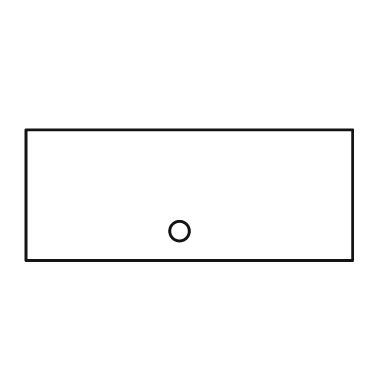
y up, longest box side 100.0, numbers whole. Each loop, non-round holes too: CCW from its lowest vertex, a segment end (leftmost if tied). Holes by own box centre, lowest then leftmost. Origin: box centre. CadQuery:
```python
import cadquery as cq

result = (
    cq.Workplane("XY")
    .moveTo(-50.0, -20.0)
    .lineTo(50.0, -20.0)
    .lineTo(50.0, 20.0)
    .lineTo(-50.0, 20.0)
    .close()
    .moveTo(-3.0, -11.0)
    .circle(3.0)
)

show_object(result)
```